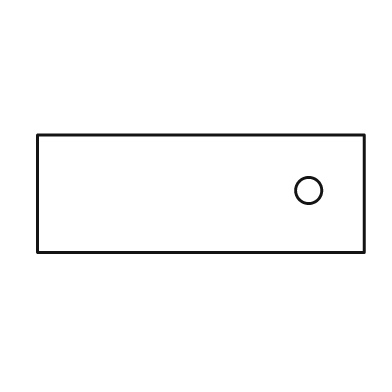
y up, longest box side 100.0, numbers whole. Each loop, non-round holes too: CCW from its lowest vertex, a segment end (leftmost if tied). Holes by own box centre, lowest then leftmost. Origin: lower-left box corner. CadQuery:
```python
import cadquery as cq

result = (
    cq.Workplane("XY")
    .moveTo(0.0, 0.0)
    .lineTo(100.0, 0.0)
    .lineTo(100.0, 36.0)
    .lineTo(0.0, 36.0)
    .close()
    .moveTo(83.0, 19.0)
    .circle(4.0)
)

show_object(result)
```